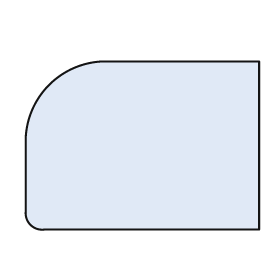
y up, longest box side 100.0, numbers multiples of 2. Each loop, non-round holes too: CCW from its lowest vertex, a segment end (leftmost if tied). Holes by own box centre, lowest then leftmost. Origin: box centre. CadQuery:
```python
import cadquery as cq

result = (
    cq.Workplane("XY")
    .moveTo(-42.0, -36.0)
    .lineTo(50.0, -36.0)
    .lineTo(50.0, 36.0)
    .lineTo(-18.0, 36.0)
    .threePointArc((-40.0, 26.0), (-50.0, 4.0))
    .lineTo(-50.0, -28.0)
    .threePointArc((-48.0, -34.0), (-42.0, -36.0))
    .close()
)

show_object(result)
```